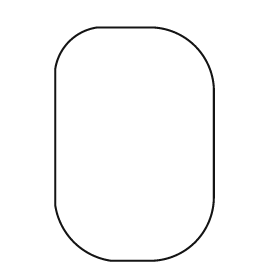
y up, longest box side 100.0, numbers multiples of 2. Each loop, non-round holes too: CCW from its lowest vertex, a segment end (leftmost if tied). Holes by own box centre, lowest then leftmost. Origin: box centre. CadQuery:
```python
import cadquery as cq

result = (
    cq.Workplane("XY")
    .moveTo(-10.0, -50.0)
    .lineTo(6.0, -50.0)
    .threePointArc((26.0, -42.0), (34.0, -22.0))
    .lineTo(34.0, 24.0)
    .threePointArc((26.0, 42.0), (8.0, 50.0))
    .lineTo(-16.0, 50.0)
    .threePointArc((-28.0, 44.0), (-34.0, 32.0))
    .lineTo(-34.0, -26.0)
    .threePointArc((-26.0, -42.0), (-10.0, -50.0))
    .close()
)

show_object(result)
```